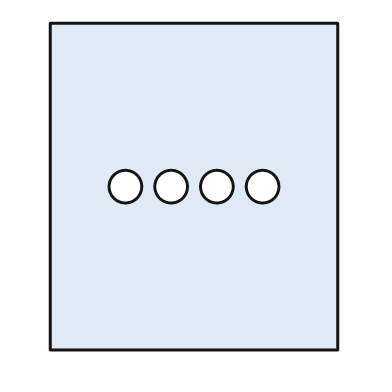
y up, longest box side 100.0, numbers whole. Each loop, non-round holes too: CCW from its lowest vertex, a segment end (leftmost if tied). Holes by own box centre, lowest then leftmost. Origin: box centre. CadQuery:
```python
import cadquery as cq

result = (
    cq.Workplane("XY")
    .moveTo(-44.0, -50.0)
    .lineTo(44.0, -50.0)
    .lineTo(44.0, 50.0)
    .lineTo(-44.0, 50.0)
    .close()
    .moveTo(-21.0, 0.0)
    .circle(5.0)
    .moveTo(-7.0, 0.0)
    .circle(5.0)
    .moveTo(7.0, 0.0)
    .circle(5.0)
    .moveTo(21.0, 0.0)
    .circle(5.0)
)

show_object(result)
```